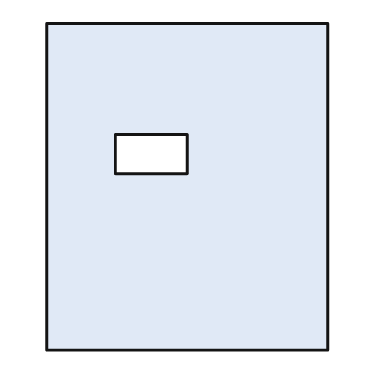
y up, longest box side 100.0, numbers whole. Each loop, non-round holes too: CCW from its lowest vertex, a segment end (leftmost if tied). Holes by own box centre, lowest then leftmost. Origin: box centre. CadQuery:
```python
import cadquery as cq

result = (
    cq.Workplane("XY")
    .moveTo(-43.0, -50.0)
    .lineTo(43.0, -50.0)
    .lineTo(43.0, 50.0)
    .lineTo(-43.0, 50.0)
    .close()
    .moveTo(-22.0, 4.0)
    .lineTo(0.0, 4.0)
    .lineTo(0.0, 16.0)
    .lineTo(-22.0, 16.0)
    .close()
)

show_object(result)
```